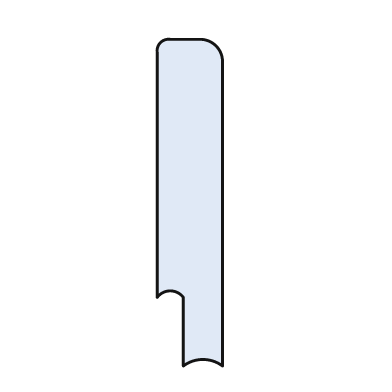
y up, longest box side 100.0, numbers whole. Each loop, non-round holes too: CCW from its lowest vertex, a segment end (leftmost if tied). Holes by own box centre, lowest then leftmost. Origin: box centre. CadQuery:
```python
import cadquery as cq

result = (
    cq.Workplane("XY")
    .moveTo(-2.0, -50.0)
    .threePointArc((4.0, -48.0), (10.0, -50.0))
    .lineTo(10.0, 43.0)
    .threePointArc((8.0, 48.0), (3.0, 50.0))
    .lineTo(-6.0, 50.0)
    .threePointArc((-9.0, 49.0), (-10.0, 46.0))
    .lineTo(-10.0, -29.0)
    .threePointArc((-6.0, -27.0), (-2.0, -29.0))
    .close()
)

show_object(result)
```